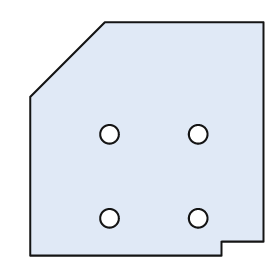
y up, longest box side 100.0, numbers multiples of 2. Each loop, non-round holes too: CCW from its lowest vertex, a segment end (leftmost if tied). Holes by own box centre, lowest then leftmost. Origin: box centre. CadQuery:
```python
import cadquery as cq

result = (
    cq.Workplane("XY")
    .moveTo(-50.0, -50.0)
    .lineTo(32.0, -50.0)
    .lineTo(32.0, -44.0)
    .lineTo(50.0, -44.0)
    .lineTo(50.0, 50.0)
    .lineTo(-18.0, 50.0)
    .lineTo(-50.0, 18.0)
    .close()
    .moveTo(-16.0, -34.0)
    .circle(4.0)
    .moveTo(22.0, -34.0)
    .circle(4.0)
    .moveTo(-16.0, 2.0)
    .circle(4.0)
    .moveTo(22.0, 2.0)
    .circle(4.0)
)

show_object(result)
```